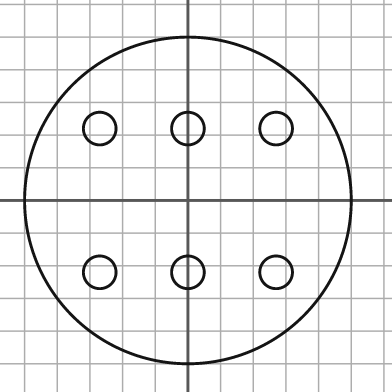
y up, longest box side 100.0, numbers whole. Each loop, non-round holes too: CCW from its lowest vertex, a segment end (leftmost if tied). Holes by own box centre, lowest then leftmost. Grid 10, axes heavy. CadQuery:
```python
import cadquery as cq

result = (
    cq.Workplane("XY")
    .moveTo(0.0, 0.0)
    .circle(50.0)
    .moveTo(-27.0, -22.0)
    .circle(5.0)
    .moveTo(0.0, -22.0)
    .circle(5.0)
    .moveTo(27.0, -22.0)
    .circle(5.0)
    .moveTo(-27.0, 22.0)
    .circle(5.0)
    .moveTo(0.0, 22.0)
    .circle(5.0)
    .moveTo(27.0, 22.0)
    .circle(5.0)
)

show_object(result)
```